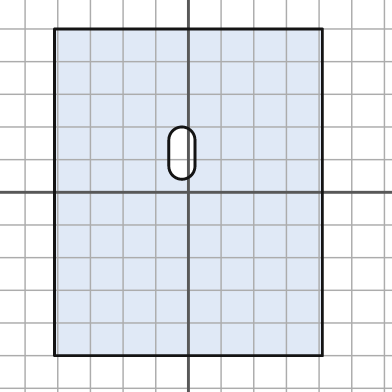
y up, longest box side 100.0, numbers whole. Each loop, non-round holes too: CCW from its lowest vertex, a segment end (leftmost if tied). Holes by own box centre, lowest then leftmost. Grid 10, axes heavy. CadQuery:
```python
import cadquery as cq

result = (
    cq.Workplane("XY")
    .moveTo(-41.0, -50.0)
    .lineTo(41.0, -50.0)
    .lineTo(41.0, 50.0)
    .lineTo(-41.0, 50.0)
    .close()
    .moveTo(-6.0, 8.0)
    .threePointArc((-2.0, 4.0), (2.0, 8.0))
    .lineTo(2.0, 16.0)
    .threePointArc((-2.0, 20.0), (-6.0, 16.0))
    .close()
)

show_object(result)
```